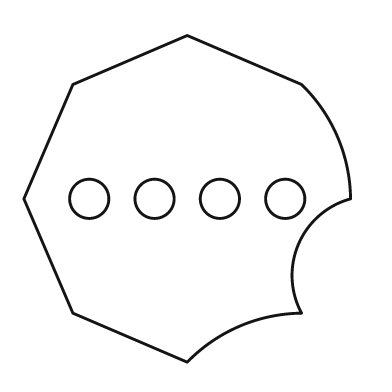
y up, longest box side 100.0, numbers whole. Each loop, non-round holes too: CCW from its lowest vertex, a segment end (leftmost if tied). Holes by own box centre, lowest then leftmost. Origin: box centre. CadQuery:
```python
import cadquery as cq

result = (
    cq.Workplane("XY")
    .moveTo(0.0, -50.0)
    .threePointArc((16.0, -39.0), (35.0, -35.0))
    .threePointArc((34.0, -14.0), (50.0, 0.0))
    .threePointArc((46.0, 19.0), (35.0, 35.0))
    .lineTo(0.0, 50.0)
    .lineTo(-35.0, 35.0)
    .lineTo(-50.0, 0.0)
    .lineTo(-35.0, -35.0)
    .close()
    .moveTo(-30.0, 0.0)
    .circle(6.0)
    .moveTo(-10.0, 0.0)
    .circle(6.0)
    .moveTo(10.0, 0.0)
    .circle(6.0)
    .moveTo(30.0, 0.0)
    .circle(6.0)
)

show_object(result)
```